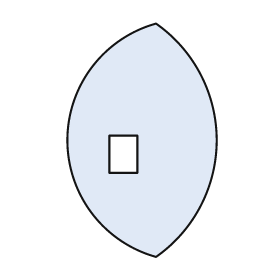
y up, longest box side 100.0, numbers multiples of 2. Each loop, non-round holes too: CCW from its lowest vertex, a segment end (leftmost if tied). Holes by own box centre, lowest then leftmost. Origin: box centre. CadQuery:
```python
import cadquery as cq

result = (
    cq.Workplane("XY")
    .moveTo(6.0, -50.0)
    .threePointArc((32.0, 0.0), (6.0, 50.0))
    .threePointArc((-32.0, 0.0), (6.0, -50.0))
    .close()
    .moveTo(-14.0, -14.0)
    .lineTo(-2.0, -14.0)
    .lineTo(-2.0, 2.0)
    .lineTo(-14.0, 2.0)
    .close()
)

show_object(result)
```